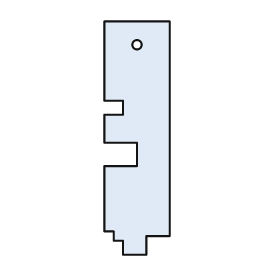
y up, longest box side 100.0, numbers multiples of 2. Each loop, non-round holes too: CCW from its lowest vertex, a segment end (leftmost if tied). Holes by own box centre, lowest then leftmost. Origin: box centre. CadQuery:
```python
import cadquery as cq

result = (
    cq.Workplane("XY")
    .moveTo(-6.0, -50.0)
    .lineTo(4.0, -50.0)
    .lineTo(4.0, -42.0)
    .lineTo(14.0, -42.0)
    .lineTo(14.0, 50.0)
    .lineTo(-14.0, 50.0)
    .lineTo(-14.0, 16.0)
    .lineTo(-6.0, 16.0)
    .lineTo(-6.0, 10.0)
    .lineTo(-14.0, 10.0)
    .lineTo(-14.0, -2.0)
    .lineTo(0.0, -2.0)
    .lineTo(0.0, -12.0)
    .lineTo(-14.0, -12.0)
    .lineTo(-14.0, -40.0)
    .lineTo(-10.0, -40.0)
    .lineTo(-10.0, -44.0)
    .lineTo(-6.0, -44.0)
    .close()
    .moveTo(0.0, 40.0)
    .circle(2.0)
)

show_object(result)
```